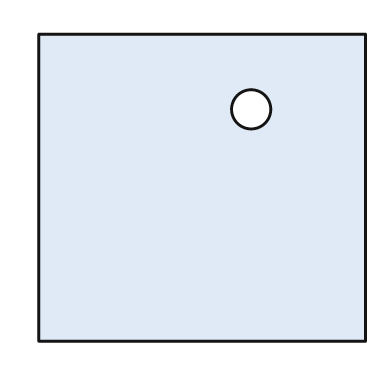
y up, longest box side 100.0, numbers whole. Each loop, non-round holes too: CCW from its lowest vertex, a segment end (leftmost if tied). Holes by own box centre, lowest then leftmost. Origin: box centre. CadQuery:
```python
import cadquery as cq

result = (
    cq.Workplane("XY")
    .moveTo(-50.0, -47.0)
    .lineTo(50.0, -47.0)
    .lineTo(50.0, 47.0)
    .lineTo(-50.0, 47.0)
    .close()
    .moveTo(15.0, 24.0)
    .circle(6.0)
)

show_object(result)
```